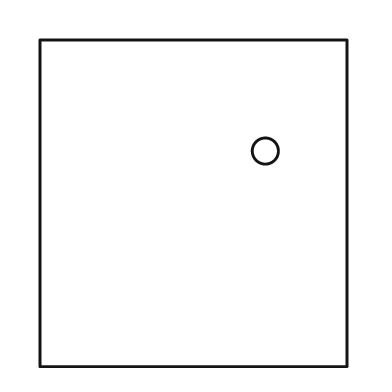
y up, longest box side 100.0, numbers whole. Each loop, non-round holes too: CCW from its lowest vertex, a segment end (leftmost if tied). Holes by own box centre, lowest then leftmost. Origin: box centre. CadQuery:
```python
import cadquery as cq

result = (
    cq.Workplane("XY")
    .moveTo(-47.0, -50.0)
    .lineTo(47.0, -50.0)
    .lineTo(47.0, 50.0)
    .lineTo(-47.0, 50.0)
    .close()
    .moveTo(22.0, 16.0)
    .circle(4.0)
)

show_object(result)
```